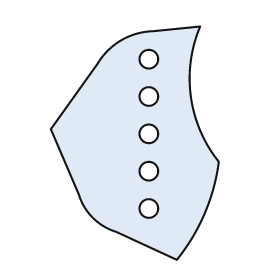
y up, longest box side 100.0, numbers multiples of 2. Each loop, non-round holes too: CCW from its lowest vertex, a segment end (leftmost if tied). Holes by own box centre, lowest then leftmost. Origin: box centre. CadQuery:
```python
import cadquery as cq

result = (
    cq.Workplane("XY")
    .moveTo(18.0, -50.0)
    .threePointArc((30.0, -30.0), (36.0, -8.0))
    .threePointArc((24.0, 20.0), (28.0, 50.0))
    .lineTo(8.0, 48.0)
    .threePointArc((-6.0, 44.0), (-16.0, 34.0))
    .lineTo(-36.0, 6.0)
    .lineTo(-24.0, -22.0)
    .threePointArc((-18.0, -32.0), (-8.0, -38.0))
    .close()
    .moveTo(6.0, -28.0)
    .circle(4.0)
    .moveTo(6.0, -12.0)
    .circle(4.0)
    .moveTo(6.0, 4.0)
    .circle(4.0)
    .moveTo(6.0, 20.0)
    .circle(4.0)
    .moveTo(6.0, 36.0)
    .circle(4.0)
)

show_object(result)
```